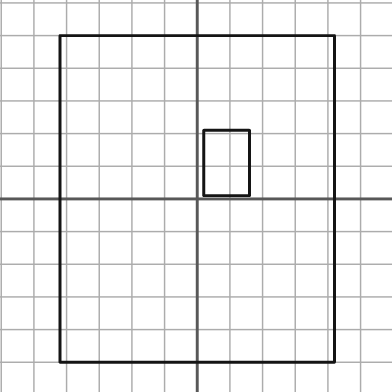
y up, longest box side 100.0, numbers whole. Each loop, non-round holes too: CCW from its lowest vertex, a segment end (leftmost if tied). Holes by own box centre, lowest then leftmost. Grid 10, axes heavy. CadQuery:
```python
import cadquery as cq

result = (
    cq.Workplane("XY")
    .moveTo(-42.0, -50.0)
    .lineTo(42.0, -50.0)
    .lineTo(42.0, 50.0)
    .lineTo(-42.0, 50.0)
    .close()
    .moveTo(2.0, 1.0)
    .lineTo(16.0, 1.0)
    .lineTo(16.0, 21.0)
    .lineTo(2.0, 21.0)
    .close()
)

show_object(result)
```